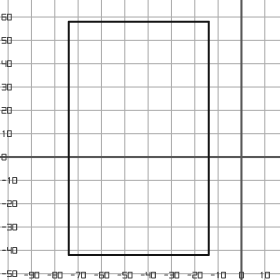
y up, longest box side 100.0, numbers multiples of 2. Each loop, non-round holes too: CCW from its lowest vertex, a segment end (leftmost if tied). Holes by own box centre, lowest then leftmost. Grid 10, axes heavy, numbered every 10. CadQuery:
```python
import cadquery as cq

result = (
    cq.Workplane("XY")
    .moveTo(-74.0, -42.0)
    .lineTo(-14.0, -42.0)
    .lineTo(-14.0, 58.0)
    .lineTo(-74.0, 58.0)
    .close()
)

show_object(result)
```